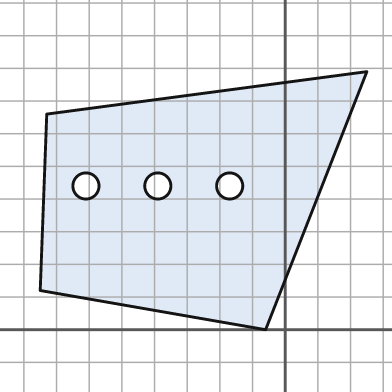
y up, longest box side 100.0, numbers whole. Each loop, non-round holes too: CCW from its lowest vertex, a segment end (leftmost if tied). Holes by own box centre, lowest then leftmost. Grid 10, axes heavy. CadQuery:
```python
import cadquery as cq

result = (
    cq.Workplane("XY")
    .moveTo(-6.0, 0.0)
    .lineTo(25.0, 79.0)
    .lineTo(-73.0, 66.0)
    .lineTo(-75.0, 12.0)
    .close()
    .moveTo(-61.0, 44.0)
    .circle(4.0)
    .moveTo(-39.0, 44.0)
    .circle(4.0)
    .moveTo(-17.0, 44.0)
    .circle(4.0)
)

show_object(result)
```